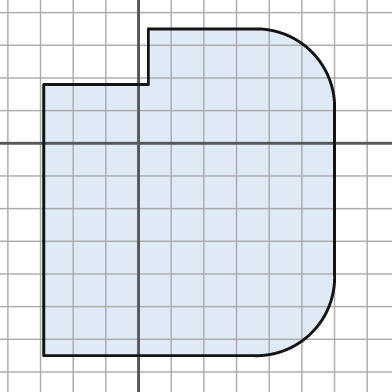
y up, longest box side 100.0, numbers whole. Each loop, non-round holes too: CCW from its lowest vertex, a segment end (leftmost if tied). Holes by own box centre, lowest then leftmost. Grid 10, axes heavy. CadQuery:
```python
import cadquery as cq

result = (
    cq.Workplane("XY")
    .moveTo(-29.0, -65.0)
    .lineTo(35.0, -65.0)
    .threePointArc((53.0, -58.0), (60.0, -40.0))
    .lineTo(60.0, 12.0)
    .threePointArc((53.0, 28.0), (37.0, 35.0))
    .lineTo(3.0, 35.0)
    .lineTo(3.0, 18.0)
    .lineTo(-29.0, 18.0)
    .close()
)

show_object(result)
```